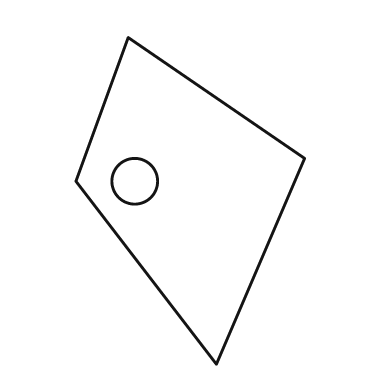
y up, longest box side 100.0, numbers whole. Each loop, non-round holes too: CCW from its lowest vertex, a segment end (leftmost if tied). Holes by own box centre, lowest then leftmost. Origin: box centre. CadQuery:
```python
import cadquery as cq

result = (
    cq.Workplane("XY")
    .moveTo(8.0, -50.0)
    .lineTo(35.0, 13.0)
    .lineTo(-19.0, 50.0)
    .lineTo(-35.0, 6.0)
    .close()
    .moveTo(-17.0, 6.0)
    .circle(7.0)
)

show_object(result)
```